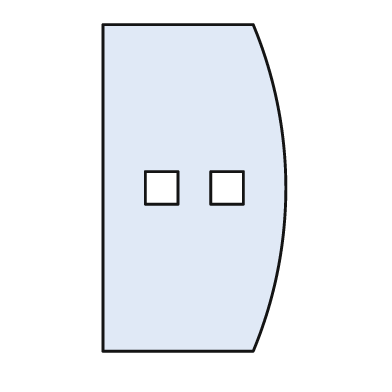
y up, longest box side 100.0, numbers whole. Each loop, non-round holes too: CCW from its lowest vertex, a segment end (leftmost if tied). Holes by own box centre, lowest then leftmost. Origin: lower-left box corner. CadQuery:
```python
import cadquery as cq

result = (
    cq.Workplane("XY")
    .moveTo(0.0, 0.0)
    .lineTo(46.0, 0.0)
    .threePointArc((56.0, 50.0), (46.0, 100.0))
    .lineTo(0.0, 100.0)
    .close()
    .moveTo(13.0, 45.0)
    .lineTo(23.0, 45.0)
    .lineTo(23.0, 55.0)
    .lineTo(13.0, 55.0)
    .close()
    .moveTo(33.0, 45.0)
    .lineTo(43.0, 45.0)
    .lineTo(43.0, 55.0)
    .lineTo(33.0, 55.0)
    .close()
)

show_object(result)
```